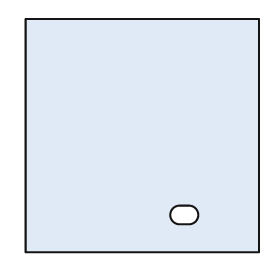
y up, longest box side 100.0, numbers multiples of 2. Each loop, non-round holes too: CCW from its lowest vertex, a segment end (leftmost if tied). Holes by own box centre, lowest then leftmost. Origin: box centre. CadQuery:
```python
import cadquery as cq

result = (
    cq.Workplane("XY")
    .moveTo(-50.0, -50.0)
    .lineTo(50.0, -50.0)
    .lineTo(50.0, 50.0)
    .lineTo(-50.0, 50.0)
    .close()
    .moveTo(16.0, -38.0)
    .lineTo(20.0, -38.0)
    .threePointArc((24.0, -34.0), (20.0, -30.0))
    .lineTo(16.0, -30.0)
    .threePointArc((12.0, -34.0), (16.0, -38.0))
    .close()
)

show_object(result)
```